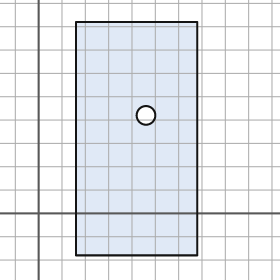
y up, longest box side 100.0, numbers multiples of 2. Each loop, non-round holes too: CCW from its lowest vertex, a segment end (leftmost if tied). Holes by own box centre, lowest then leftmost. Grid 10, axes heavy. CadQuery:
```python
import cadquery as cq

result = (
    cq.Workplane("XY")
    .moveTo(16.0, -18.0)
    .lineTo(68.0, -18.0)
    .lineTo(68.0, 82.0)
    .lineTo(16.0, 82.0)
    .close()
    .moveTo(46.0, 42.0)
    .circle(4.0)
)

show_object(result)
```